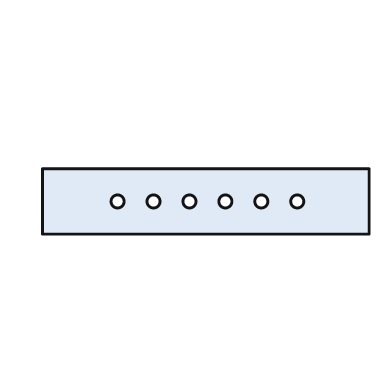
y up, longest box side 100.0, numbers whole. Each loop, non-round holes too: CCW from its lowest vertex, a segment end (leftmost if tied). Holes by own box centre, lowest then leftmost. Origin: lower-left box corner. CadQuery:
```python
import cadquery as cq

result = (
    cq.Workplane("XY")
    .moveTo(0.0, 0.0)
    .lineTo(100.0, 0.0)
    .lineTo(100.0, 20.0)
    .lineTo(0.0, 20.0)
    .close()
    .moveTo(23.0, 10.0)
    .circle(2.0)
    .moveTo(34.0, 10.0)
    .circle(2.0)
    .moveTo(45.0, 10.0)
    .circle(2.0)
    .moveTo(56.0, 10.0)
    .circle(2.0)
    .moveTo(67.0, 10.0)
    .circle(2.0)
    .moveTo(78.0, 10.0)
    .circle(2.0)
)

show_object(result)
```